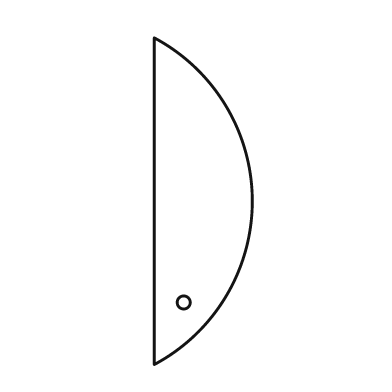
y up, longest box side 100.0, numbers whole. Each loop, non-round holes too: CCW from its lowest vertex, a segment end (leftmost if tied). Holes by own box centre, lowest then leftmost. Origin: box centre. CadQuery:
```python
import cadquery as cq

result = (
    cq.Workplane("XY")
    .moveTo(-15.0, -50.0)
    .threePointArc((15.0, 0.0), (-15.0, 50.0))
    .close()
    .moveTo(-6.0, -31.0)
    .circle(2.0)
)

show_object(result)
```